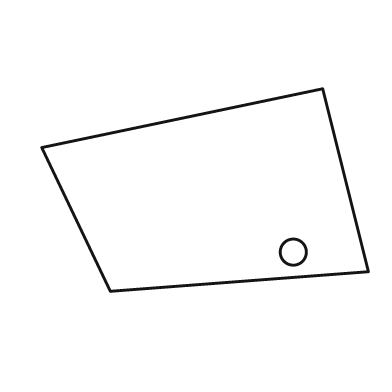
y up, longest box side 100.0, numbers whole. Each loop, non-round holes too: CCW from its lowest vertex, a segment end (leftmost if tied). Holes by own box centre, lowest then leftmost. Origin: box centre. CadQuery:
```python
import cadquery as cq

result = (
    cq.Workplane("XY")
    .moveTo(-29.0, -31.0)
    .lineTo(50.0, -25.0)
    .lineTo(36.0, 31.0)
    .lineTo(-50.0, 13.0)
    .close()
    .moveTo(27.0, -19.0)
    .circle(4.0)
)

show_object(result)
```